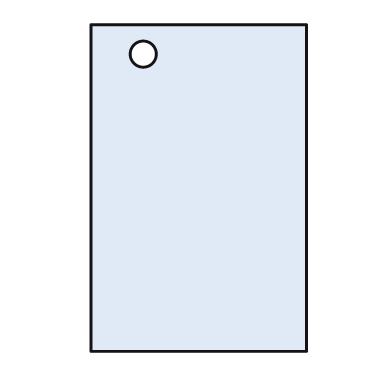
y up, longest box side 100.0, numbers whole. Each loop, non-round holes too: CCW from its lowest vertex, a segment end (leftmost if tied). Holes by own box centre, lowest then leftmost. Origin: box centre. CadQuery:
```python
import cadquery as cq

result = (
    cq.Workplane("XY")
    .moveTo(-33.0, -50.0)
    .lineTo(33.0, -50.0)
    .lineTo(33.0, 50.0)
    .lineTo(-33.0, 50.0)
    .close()
    .moveTo(-17.0, 41.0)
    .circle(4.0)
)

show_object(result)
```